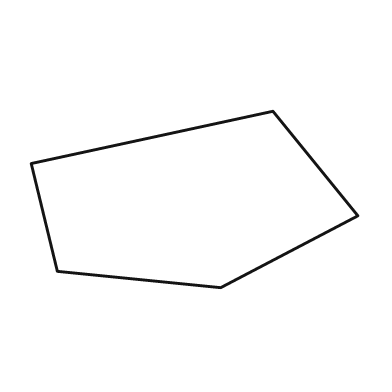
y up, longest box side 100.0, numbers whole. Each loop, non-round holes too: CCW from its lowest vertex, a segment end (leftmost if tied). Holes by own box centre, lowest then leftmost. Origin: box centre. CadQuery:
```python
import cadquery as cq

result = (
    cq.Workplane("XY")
    .moveTo(8.0, -27.0)
    .lineTo(50.0, -5.0)
    .lineTo(24.0, 27.0)
    .lineTo(-50.0, 11.0)
    .lineTo(-42.0, -22.0)
    .close()
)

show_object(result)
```